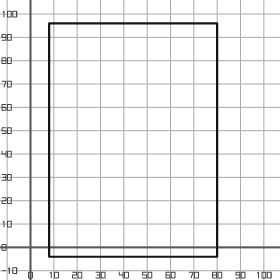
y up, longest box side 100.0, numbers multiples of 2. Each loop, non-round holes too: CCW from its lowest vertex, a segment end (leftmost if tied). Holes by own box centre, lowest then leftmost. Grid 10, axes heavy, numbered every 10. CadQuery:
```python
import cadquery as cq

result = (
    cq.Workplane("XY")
    .moveTo(8.0, -4.0)
    .lineTo(80.0, -4.0)
    .lineTo(80.0, 96.0)
    .lineTo(8.0, 96.0)
    .close()
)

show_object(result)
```